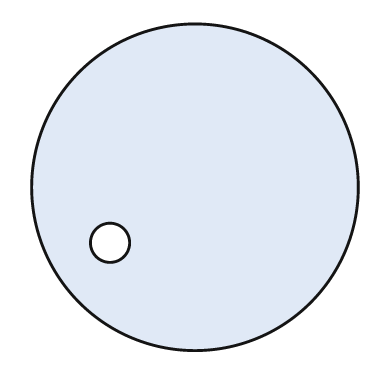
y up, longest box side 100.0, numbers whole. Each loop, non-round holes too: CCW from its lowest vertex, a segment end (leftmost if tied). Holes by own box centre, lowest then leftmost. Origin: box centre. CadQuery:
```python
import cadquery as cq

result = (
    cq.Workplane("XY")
    .moveTo(0.0, 0.0)
    .circle(50.0)
    .moveTo(-26.0, -17.0)
    .circle(6.0)
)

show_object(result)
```